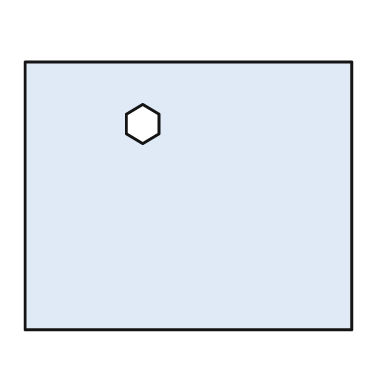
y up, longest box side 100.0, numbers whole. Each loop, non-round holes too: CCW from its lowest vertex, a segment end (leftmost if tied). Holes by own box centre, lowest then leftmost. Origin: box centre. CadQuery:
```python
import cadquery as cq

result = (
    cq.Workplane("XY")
    .moveTo(-50.0, -41.0)
    .lineTo(50.0, -41.0)
    .lineTo(50.0, 41.0)
    .lineTo(-50.0, 41.0)
    .close()
    .moveTo(-14.0, 16.0)
    .lineTo(-9.0, 19.0)
    .lineTo(-9.0, 25.0)
    .lineTo(-14.0, 28.0)
    .lineTo(-19.0, 25.0)
    .lineTo(-19.0, 19.0)
    .close()
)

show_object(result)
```